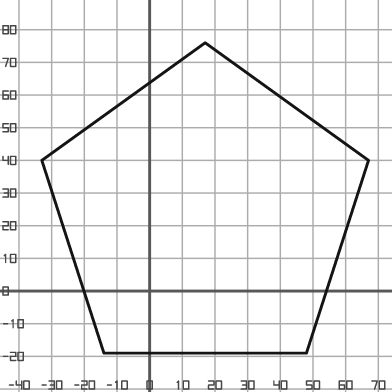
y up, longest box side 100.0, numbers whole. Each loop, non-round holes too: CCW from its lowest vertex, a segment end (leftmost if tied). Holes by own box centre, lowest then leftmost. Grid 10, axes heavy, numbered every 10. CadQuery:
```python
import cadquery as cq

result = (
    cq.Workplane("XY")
    .moveTo(-14.0, -19.0)
    .lineTo(48.0, -19.0)
    .lineTo(67.0, 40.0)
    .lineTo(17.0, 76.0)
    .lineTo(-33.0, 40.0)
    .close()
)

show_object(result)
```